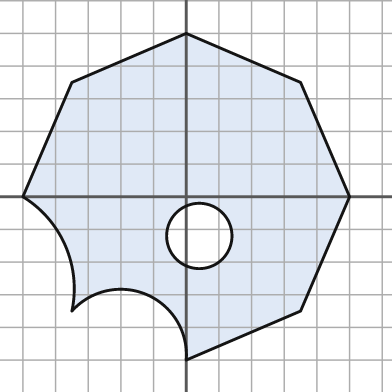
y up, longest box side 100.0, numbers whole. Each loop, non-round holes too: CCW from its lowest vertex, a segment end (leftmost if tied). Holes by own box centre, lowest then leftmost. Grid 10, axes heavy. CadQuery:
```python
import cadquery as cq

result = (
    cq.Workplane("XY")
    .moveTo(0.0, -50.0)
    .lineTo(35.0, -35.0)
    .lineTo(50.0, 0.0)
    .lineTo(35.0, 35.0)
    .lineTo(0.0, 50.0)
    .lineTo(-35.0, 35.0)
    .lineTo(-50.0, 0.0)
    .threePointArc((-37.0, -15.0), (-35.0, -35.0))
    .threePointArc((-12.0, -30.0), (0.0, -50.0))
    .close()
    .moveTo(4.0, -12.0)
    .circle(10.0)
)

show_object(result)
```